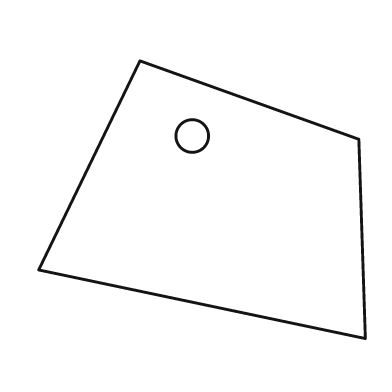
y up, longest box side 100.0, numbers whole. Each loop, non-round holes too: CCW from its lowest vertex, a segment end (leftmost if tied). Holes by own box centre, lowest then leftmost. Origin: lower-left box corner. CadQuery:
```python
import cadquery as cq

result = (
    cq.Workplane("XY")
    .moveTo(100.0, 0.0)
    .lineTo(98.0, 61.0)
    .lineTo(31.0, 85.0)
    .lineTo(0.0, 21.0)
    .close()
    .moveTo(47.0, 62.0)
    .circle(5.0)
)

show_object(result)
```